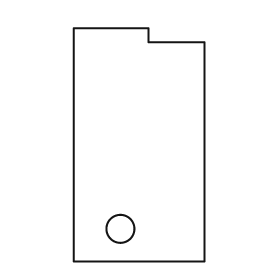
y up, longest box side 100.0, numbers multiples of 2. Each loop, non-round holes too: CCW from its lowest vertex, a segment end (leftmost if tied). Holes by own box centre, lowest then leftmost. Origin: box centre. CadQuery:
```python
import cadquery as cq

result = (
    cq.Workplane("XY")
    .moveTo(-28.0, -50.0)
    .lineTo(28.0, -50.0)
    .lineTo(28.0, 44.0)
    .lineTo(4.0, 44.0)
    .lineTo(4.0, 50.0)
    .lineTo(-28.0, 50.0)
    .close()
    .moveTo(-8.0, -36.0)
    .circle(6.0)
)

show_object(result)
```